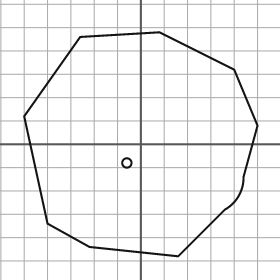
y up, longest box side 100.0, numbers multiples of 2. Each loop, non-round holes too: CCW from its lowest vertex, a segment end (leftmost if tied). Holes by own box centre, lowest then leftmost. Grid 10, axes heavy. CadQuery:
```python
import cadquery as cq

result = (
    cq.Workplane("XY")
    .moveTo(16.0, -48.0)
    .lineTo(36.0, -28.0)
    .threePointArc((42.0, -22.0), (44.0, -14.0))
    .lineTo(50.0, 8.0)
    .lineTo(40.0, 32.0)
    .lineTo(8.0, 48.0)
    .lineTo(-26.0, 46.0)
    .lineTo(-50.0, 12.0)
    .lineTo(-40.0, -34.0)
    .lineTo(-22.0, -44.0)
    .close()
    .moveTo(-6.0, -8.0)
    .circle(2.0)
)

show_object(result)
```